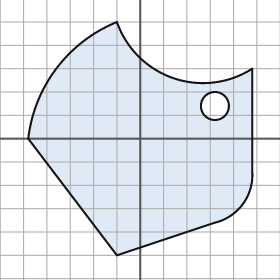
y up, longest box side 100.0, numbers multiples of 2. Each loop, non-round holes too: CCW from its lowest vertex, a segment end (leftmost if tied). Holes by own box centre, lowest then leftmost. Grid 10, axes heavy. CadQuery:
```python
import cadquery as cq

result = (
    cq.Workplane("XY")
    .moveTo(-10.0, -50.0)
    .lineTo(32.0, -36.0)
    .threePointArc((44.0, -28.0), (48.0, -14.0))
    .lineTo(48.0, 30.0)
    .threePointArc((14.0, 26.0), (-10.0, 50.0))
    .threePointArc((-36.0, 30.0), (-48.0, 0.0))
    .close()
    .moveTo(32.0, 14.0)
    .circle(6.0)
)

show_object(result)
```